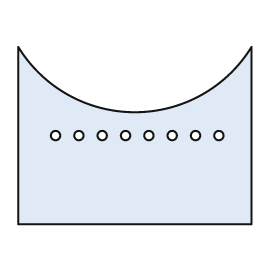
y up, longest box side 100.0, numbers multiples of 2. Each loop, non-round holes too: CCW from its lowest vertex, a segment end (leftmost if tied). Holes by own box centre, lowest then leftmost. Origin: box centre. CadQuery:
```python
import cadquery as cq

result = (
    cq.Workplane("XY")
    .moveTo(-50.0, -38.0)
    .lineTo(50.0, -38.0)
    .lineTo(50.0, 38.0)
    .threePointArc((0.0, 10.0), (-50.0, 38.0))
    .close()
    .moveTo(-34.0, 0.0)
    .circle(2.0)
    .moveTo(-24.0, 0.0)
    .circle(2.0)
    .moveTo(-14.0, 0.0)
    .circle(2.0)
    .moveTo(-4.0, 0.0)
    .circle(2.0)
    .moveTo(6.0, 0.0)
    .circle(2.0)
    .moveTo(16.0, 0.0)
    .circle(2.0)
    .moveTo(26.0, 0.0)
    .circle(2.0)
    .moveTo(36.0, 0.0)
    .circle(2.0)
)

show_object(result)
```